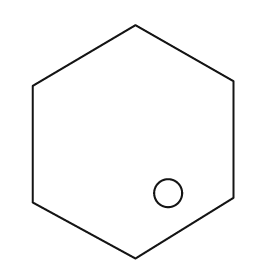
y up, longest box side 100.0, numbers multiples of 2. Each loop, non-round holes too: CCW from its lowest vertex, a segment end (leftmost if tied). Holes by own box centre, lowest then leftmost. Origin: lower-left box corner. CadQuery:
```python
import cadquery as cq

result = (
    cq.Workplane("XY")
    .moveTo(44.0, 0.0)
    .lineTo(86.0, 26.0)
    .lineTo(86.0, 76.0)
    .lineTo(44.0, 100.0)
    .lineTo(0.0, 74.0)
    .lineTo(0.0, 24.0)
    .close()
    .moveTo(58.0, 28.0)
    .circle(6.0)
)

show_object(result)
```